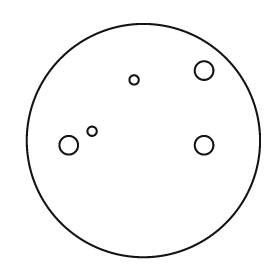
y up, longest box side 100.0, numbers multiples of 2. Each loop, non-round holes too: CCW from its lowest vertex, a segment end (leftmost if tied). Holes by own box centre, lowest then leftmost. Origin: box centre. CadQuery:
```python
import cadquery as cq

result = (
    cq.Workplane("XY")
    .moveTo(0.0, 0.0)
    .circle(50.0)
    .moveTo(-32.0, -2.0)
    .circle(4.0)
    .moveTo(26.0, -2.0)
    .circle(4.0)
    .moveTo(-22.0, 4.0)
    .circle(2.0)
    .moveTo(-4.0, 26.0)
    .circle(2.0)
    .moveTo(26.0, 30.0)
    .circle(4.0)
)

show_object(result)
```